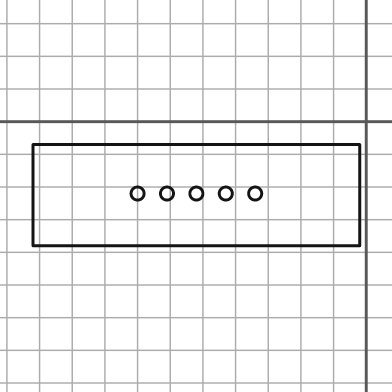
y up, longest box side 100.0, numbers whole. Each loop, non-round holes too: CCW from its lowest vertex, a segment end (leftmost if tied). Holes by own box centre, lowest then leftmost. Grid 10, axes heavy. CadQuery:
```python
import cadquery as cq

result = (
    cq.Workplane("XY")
    .moveTo(-102.0, -38.0)
    .lineTo(-2.0, -38.0)
    .lineTo(-2.0, -7.0)
    .lineTo(-102.0, -7.0)
    .close()
    .moveTo(-70.0, -22.0)
    .circle(2.0)
    .moveTo(-61.0, -22.0)
    .circle(2.0)
    .moveTo(-52.0, -22.0)
    .circle(2.0)
    .moveTo(-43.0, -22.0)
    .circle(2.0)
    .moveTo(-34.0, -22.0)
    .circle(2.0)
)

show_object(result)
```